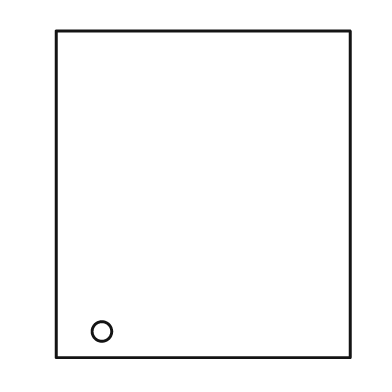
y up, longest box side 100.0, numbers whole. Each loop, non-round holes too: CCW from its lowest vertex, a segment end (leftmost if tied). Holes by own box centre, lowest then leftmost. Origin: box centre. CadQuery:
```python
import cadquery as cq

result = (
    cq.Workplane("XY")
    .moveTo(-45.0, -50.0)
    .lineTo(45.0, -50.0)
    .lineTo(45.0, 50.0)
    .lineTo(-45.0, 50.0)
    .close()
    .moveTo(-31.0, -42.0)
    .circle(3.0)
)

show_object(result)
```